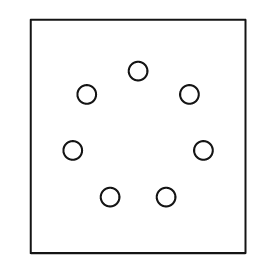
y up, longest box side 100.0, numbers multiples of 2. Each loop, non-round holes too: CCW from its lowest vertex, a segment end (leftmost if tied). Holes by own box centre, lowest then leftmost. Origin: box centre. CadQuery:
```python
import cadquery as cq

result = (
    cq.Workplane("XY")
    .moveTo(-46.0, -50.0)
    .lineTo(46.0, -50.0)
    .lineTo(46.0, 50.0)
    .lineTo(-46.0, 50.0)
    .close()
    .moveTo(-12.0, -26.0)
    .circle(4.0)
    .moveTo(12.0, -26.0)
    .circle(4.0)
    .moveTo(-28.0, -6.0)
    .circle(4.0)
    .moveTo(28.0, -6.0)
    .circle(4.0)
    .moveTo(-22.0, 18.0)
    .circle(4.0)
    .moveTo(22.0, 18.0)
    .circle(4.0)
    .moveTo(0.0, 28.0)
    .circle(4.0)
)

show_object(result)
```